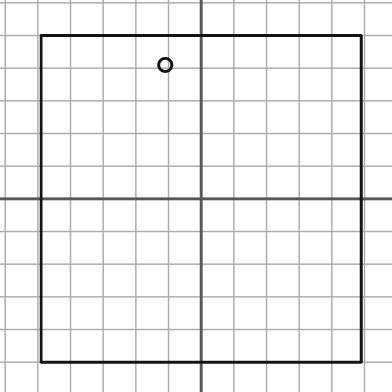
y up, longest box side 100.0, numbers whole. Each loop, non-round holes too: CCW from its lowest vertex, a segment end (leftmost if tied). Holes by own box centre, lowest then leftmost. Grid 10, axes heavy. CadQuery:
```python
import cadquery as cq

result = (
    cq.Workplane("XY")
    .moveTo(-49.0, -50.0)
    .lineTo(49.0, -50.0)
    .lineTo(49.0, 50.0)
    .lineTo(-49.0, 50.0)
    .close()
    .moveTo(-11.0, 41.0)
    .circle(2.0)
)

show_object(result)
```